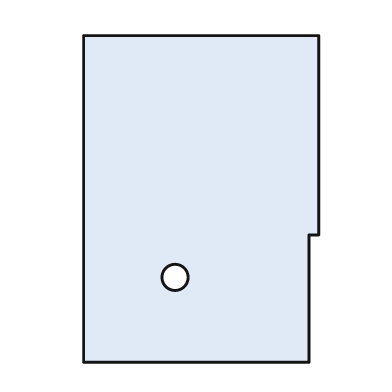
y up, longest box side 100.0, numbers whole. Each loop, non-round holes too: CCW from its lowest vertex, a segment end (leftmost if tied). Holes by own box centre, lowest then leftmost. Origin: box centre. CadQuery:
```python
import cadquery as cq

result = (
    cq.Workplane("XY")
    .moveTo(-36.0, -50.0)
    .lineTo(33.0, -50.0)
    .lineTo(33.0, -11.0)
    .lineTo(36.0, -11.0)
    .lineTo(36.0, 50.0)
    .lineTo(-36.0, 50.0)
    .close()
    .moveTo(-8.0, -24.0)
    .circle(4.0)
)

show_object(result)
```